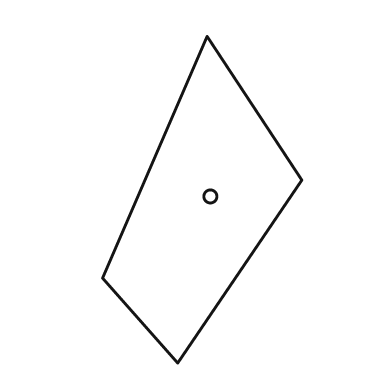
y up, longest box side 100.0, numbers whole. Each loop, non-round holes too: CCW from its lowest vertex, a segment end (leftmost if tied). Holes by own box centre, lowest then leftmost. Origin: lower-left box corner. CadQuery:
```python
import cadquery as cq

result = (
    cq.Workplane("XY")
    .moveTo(23.0, 0.0)
    .lineTo(61.0, 56.0)
    .lineTo(32.0, 100.0)
    .lineTo(0.0, 26.0)
    .close()
    .moveTo(33.0, 51.0)
    .circle(2.0)
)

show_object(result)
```